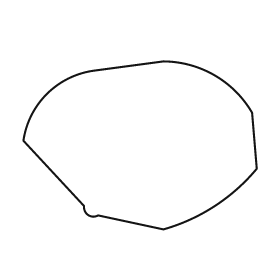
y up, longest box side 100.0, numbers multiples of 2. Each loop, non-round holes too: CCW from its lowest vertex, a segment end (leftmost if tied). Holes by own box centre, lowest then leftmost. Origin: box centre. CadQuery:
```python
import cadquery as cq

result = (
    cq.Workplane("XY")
    .moveTo(10.0, -36.0)
    .threePointArc((32.0, -26.0), (50.0, -10.0))
    .lineTo(48.0, 14.0)
    .threePointArc((32.0, 30.0), (10.0, 36.0))
    .lineTo(-20.0, 32.0)
    .threePointArc((-40.0, 22.0), (-50.0, 2.0))
    .lineTo(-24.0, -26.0)
    .threePointArc((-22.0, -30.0), (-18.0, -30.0))
    .close()
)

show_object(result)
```